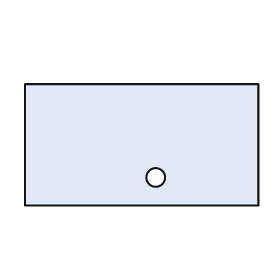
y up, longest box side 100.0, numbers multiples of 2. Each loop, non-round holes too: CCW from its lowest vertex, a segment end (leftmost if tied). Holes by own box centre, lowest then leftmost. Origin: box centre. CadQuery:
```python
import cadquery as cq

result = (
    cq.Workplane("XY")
    .moveTo(-50.0, -26.0)
    .lineTo(50.0, -26.0)
    .lineTo(50.0, 26.0)
    .lineTo(-50.0, 26.0)
    .close()
    .moveTo(6.0, -14.0)
    .circle(4.0)
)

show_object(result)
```